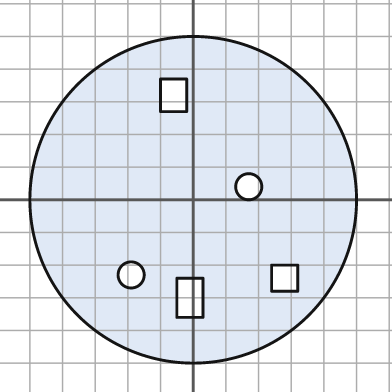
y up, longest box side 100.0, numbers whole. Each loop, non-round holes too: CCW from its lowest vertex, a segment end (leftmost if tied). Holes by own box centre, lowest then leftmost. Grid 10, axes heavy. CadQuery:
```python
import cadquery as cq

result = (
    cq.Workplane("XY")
    .moveTo(0.0, 0.0)
    .circle(50.0)
    .moveTo(-5.0, -36.0)
    .lineTo(3.0, -36.0)
    .lineTo(3.0, -24.0)
    .lineTo(-5.0, -24.0)
    .close()
    .moveTo(24.0, -28.0)
    .lineTo(32.0, -28.0)
    .lineTo(32.0, -20.0)
    .lineTo(24.0, -20.0)
    .close()
    .moveTo(-19.0, -23.0)
    .circle(4.0)
    .moveTo(17.0, 4.0)
    .circle(4.0)
    .moveTo(-10.0, 27.0)
    .lineTo(-2.0, 27.0)
    .lineTo(-2.0, 37.0)
    .lineTo(-10.0, 37.0)
    .close()
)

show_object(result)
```